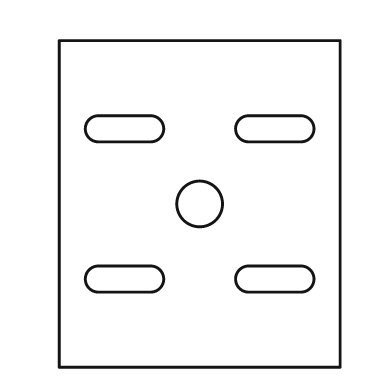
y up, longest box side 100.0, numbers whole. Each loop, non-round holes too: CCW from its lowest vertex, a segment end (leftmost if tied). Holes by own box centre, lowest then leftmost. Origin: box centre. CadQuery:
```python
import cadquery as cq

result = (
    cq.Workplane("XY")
    .moveTo(-43.0, -50.0)
    .lineTo(43.0, -50.0)
    .lineTo(43.0, 50.0)
    .lineTo(-43.0, 50.0)
    .close()
    .moveTo(-31.0, -27.0)
    .lineTo(-15.0, -27.0)
    .threePointArc((-11.0, -23.0), (-15.0, -19.0))
    .lineTo(-31.0, -19.0)
    .threePointArc((-35.0, -23.0), (-31.0, -27.0))
    .close()
    .moveTo(15.0, -27.0)
    .lineTo(31.0, -27.0)
    .threePointArc((35.0, -23.0), (31.0, -19.0))
    .lineTo(15.0, -19.0)
    .threePointArc((11.0, -23.0), (15.0, -27.0))
    .close()
    .moveTo(0.0, 0.0)
    .circle(7.0)
    .moveTo(-31.0, 19.0)
    .lineTo(-15.0, 19.0)
    .threePointArc((-11.0, 23.0), (-15.0, 27.0))
    .lineTo(-31.0, 27.0)
    .threePointArc((-35.0, 23.0), (-31.0, 19.0))
    .close()
    .moveTo(15.0, 19.0)
    .lineTo(31.0, 19.0)
    .threePointArc((35.0, 23.0), (31.0, 27.0))
    .lineTo(15.0, 27.0)
    .threePointArc((11.0, 23.0), (15.0, 19.0))
    .close()
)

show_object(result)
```